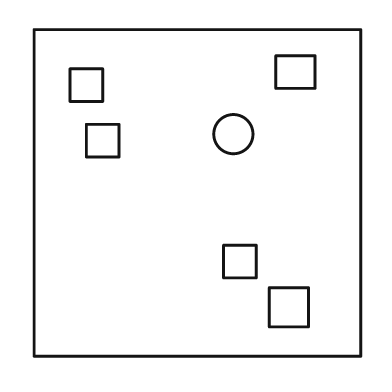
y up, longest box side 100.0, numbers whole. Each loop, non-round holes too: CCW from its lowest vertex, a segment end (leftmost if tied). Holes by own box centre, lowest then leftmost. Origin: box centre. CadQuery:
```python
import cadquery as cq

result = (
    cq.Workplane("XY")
    .moveTo(-50.0, -50.0)
    .lineTo(50.0, -50.0)
    .lineTo(50.0, 50.0)
    .lineTo(-50.0, 50.0)
    .close()
    .moveTo(22.0, -41.0)
    .lineTo(34.0, -41.0)
    .lineTo(34.0, -29.0)
    .lineTo(22.0, -29.0)
    .close()
    .moveTo(8.0, -26.0)
    .lineTo(18.0, -26.0)
    .lineTo(18.0, -16.0)
    .lineTo(8.0, -16.0)
    .close()
    .moveTo(-34.0, 11.0)
    .lineTo(-24.0, 11.0)
    .lineTo(-24.0, 21.0)
    .lineTo(-34.0, 21.0)
    .close()
    .moveTo(11.0, 18.0)
    .circle(6.0)
    .moveTo(-39.0, 28.0)
    .lineTo(-29.0, 28.0)
    .lineTo(-29.0, 38.0)
    .lineTo(-39.0, 38.0)
    .close()
    .moveTo(24.0, 32.0)
    .lineTo(36.0, 32.0)
    .lineTo(36.0, 42.0)
    .lineTo(24.0, 42.0)
    .close()
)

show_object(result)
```